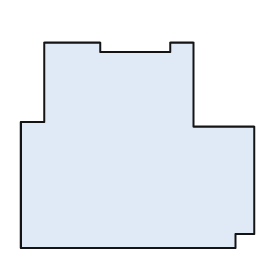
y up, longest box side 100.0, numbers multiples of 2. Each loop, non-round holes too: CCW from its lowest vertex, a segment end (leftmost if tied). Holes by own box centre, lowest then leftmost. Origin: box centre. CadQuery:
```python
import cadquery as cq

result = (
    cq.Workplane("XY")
    .moveTo(-50.0, -44.0)
    .lineTo(42.0, -44.0)
    .lineTo(42.0, -38.0)
    .lineTo(50.0, -38.0)
    .lineTo(50.0, 8.0)
    .lineTo(24.0, 8.0)
    .lineTo(24.0, 44.0)
    .lineTo(14.0, 44.0)
    .lineTo(14.0, 40.0)
    .lineTo(-16.0, 40.0)
    .lineTo(-16.0, 44.0)
    .lineTo(-40.0, 44.0)
    .lineTo(-40.0, 10.0)
    .lineTo(-50.0, 10.0)
    .close()
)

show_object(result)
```